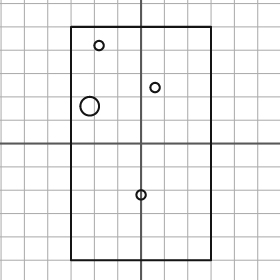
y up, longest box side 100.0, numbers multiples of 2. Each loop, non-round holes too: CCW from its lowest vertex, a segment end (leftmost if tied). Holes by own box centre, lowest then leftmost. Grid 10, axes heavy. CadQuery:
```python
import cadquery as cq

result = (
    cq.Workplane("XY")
    .moveTo(-30.0, -50.0)
    .lineTo(30.0, -50.0)
    .lineTo(30.0, 50.0)
    .lineTo(-30.0, 50.0)
    .close()
    .moveTo(0.0, -22.0)
    .circle(2.0)
    .moveTo(-22.0, 16.0)
    .circle(4.0)
    .moveTo(6.0, 24.0)
    .circle(2.0)
    .moveTo(-18.0, 42.0)
    .circle(2.0)
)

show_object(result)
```